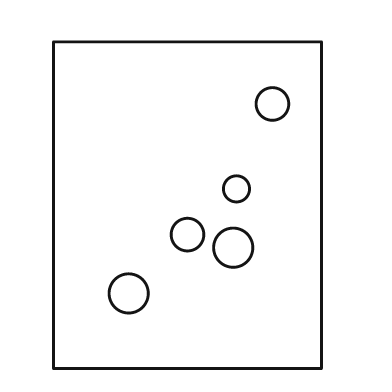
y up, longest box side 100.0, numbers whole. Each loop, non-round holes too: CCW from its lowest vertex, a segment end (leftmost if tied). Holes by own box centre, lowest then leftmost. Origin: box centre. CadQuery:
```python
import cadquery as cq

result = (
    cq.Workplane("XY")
    .moveTo(-41.0, -50.0)
    .lineTo(41.0, -50.0)
    .lineTo(41.0, 50.0)
    .lineTo(-41.0, 50.0)
    .close()
    .moveTo(-18.0, -27.0)
    .circle(6.0)
    .moveTo(14.0, -13.0)
    .circle(6.0)
    .moveTo(0.0, -9.0)
    .circle(5.0)
    .moveTo(15.0, 5.0)
    .circle(4.0)
    .moveTo(26.0, 31.0)
    .circle(5.0)
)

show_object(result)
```